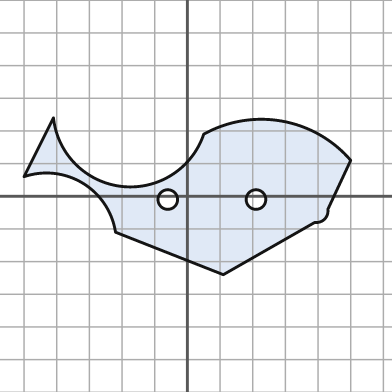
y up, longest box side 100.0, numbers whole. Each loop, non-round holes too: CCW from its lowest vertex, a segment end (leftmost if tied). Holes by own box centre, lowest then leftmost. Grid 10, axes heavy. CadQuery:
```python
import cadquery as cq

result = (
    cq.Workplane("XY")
    .moveTo(11.0, -24.0)
    .lineTo(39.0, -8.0)
    .threePointArc((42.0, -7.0), (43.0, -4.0))
    .lineTo(50.0, 11.0)
    .threePointArc((29.0, 23.0), (5.0, 19.0))
    .threePointArc((-20.0, 3.0), (-41.0, 24.0))
    .lineTo(-50.0, 6.0)
    .threePointArc((-32.0, 4.0), (-22.0, -11.0))
    .close()
    .moveTo(-6.0, -1.0)
    .circle(3.0)
    .moveTo(21.0, -1.0)
    .circle(3.0)
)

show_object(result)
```